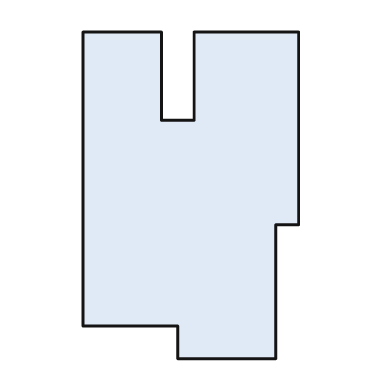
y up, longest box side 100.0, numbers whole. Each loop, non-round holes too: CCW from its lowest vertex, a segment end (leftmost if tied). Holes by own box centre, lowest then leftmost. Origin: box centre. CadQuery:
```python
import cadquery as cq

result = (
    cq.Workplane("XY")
    .moveTo(-4.0, -50.0)
    .lineTo(26.0, -50.0)
    .lineTo(26.0, -9.0)
    .lineTo(33.0, -9.0)
    .lineTo(33.0, 50.0)
    .lineTo(1.0, 50.0)
    .lineTo(1.0, 23.0)
    .lineTo(-9.0, 23.0)
    .lineTo(-9.0, 50.0)
    .lineTo(-33.0, 50.0)
    .lineTo(-33.0, -40.0)
    .lineTo(-4.0, -40.0)
    .close()
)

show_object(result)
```